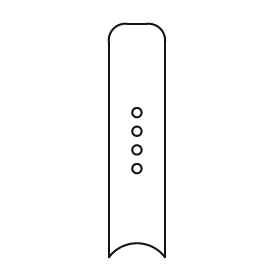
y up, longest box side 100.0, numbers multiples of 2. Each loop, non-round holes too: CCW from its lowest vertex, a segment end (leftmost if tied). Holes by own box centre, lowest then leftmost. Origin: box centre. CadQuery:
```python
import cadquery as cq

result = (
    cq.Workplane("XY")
    .moveTo(-12.0, -50.0)
    .threePointArc((0.0, -44.0), (12.0, -50.0))
    .lineTo(12.0, 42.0)
    .threePointArc((10.0, 48.0), (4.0, 50.0))
    .lineTo(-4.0, 50.0)
    .threePointArc((-10.0, 48.0), (-12.0, 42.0))
    .close()
    .moveTo(0.0, -12.0)
    .circle(2.0)
    .moveTo(0.0, -4.0)
    .circle(2.0)
    .moveTo(0.0, 4.0)
    .circle(2.0)
    .moveTo(0.0, 12.0)
    .circle(2.0)
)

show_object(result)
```